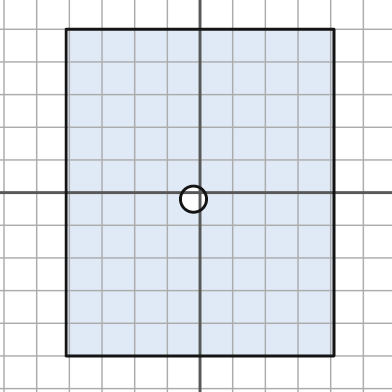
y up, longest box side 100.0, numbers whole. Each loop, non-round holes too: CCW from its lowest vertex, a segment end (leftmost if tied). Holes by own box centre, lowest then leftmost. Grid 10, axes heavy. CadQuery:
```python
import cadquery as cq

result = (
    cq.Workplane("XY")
    .moveTo(-41.0, -50.0)
    .lineTo(41.0, -50.0)
    .lineTo(41.0, 50.0)
    .lineTo(-41.0, 50.0)
    .close()
    .moveTo(-2.0, -2.0)
    .circle(4.0)
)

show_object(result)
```